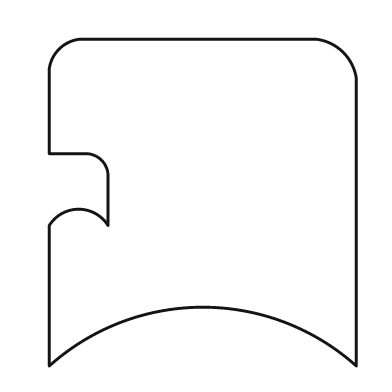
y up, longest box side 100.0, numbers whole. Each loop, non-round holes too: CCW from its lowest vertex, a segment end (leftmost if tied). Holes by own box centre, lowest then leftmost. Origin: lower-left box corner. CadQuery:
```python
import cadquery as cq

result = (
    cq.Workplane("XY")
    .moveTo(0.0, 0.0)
    .threePointArc((47.0, 18.0), (94.0, 0.0))
    .lineTo(94.0, 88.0)
    .threePointArc((90.0, 96.0), (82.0, 100.0))
    .lineTo(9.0, 100.0)
    .threePointArc((3.0, 97.0), (0.0, 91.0))
    .lineTo(0.0, 65.0)
    .lineTo(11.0, 65.0)
    .threePointArc((16.0, 63.0), (18.0, 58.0))
    .lineTo(18.0, 43.0)
    .threePointArc((9.0, 48.0), (0.0, 43.0))
    .close()
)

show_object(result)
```